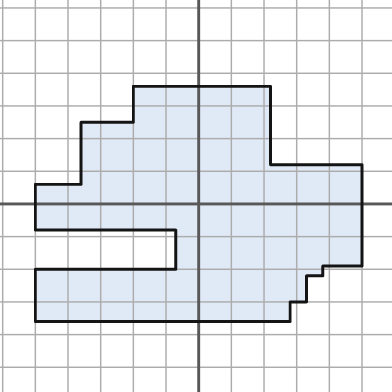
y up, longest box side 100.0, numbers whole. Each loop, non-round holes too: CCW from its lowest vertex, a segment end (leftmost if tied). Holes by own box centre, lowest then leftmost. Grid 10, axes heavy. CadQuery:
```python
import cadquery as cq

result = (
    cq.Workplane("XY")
    .moveTo(-50.0, -36.0)
    .lineTo(28.0, -36.0)
    .lineTo(28.0, -30.0)
    .lineTo(33.0, -30.0)
    .lineTo(33.0, -22.0)
    .lineTo(38.0, -22.0)
    .lineTo(38.0, -19.0)
    .lineTo(50.0, -19.0)
    .lineTo(50.0, 12.0)
    .lineTo(22.0, 12.0)
    .lineTo(22.0, 36.0)
    .lineTo(-20.0, 36.0)
    .lineTo(-20.0, 25.0)
    .lineTo(-36.0, 25.0)
    .lineTo(-36.0, 6.0)
    .lineTo(-50.0, 6.0)
    .lineTo(-50.0, -8.0)
    .lineTo(-7.0, -8.0)
    .lineTo(-7.0, -20.0)
    .lineTo(-50.0, -20.0)
    .close()
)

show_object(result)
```